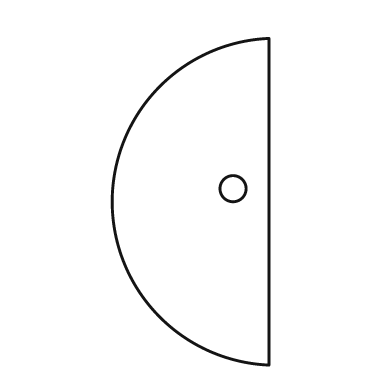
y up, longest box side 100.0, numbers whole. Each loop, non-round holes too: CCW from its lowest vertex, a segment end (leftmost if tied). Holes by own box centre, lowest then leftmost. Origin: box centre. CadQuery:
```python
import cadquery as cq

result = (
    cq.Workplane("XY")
    .moveTo(24.0, -50.0)
    .lineTo(24.0, 50.0)
    .threePointArc((-24.0, 0.0), (24.0, -50.0))
    .close()
    .moveTo(13.0, 4.0)
    .circle(4.0)
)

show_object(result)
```